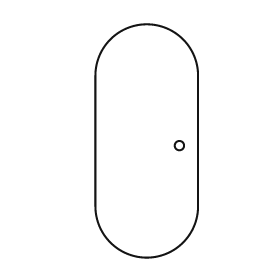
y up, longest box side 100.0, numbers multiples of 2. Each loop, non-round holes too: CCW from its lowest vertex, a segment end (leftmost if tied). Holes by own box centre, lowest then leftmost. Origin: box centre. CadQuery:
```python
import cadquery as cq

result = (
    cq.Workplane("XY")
    .moveTo(-22.0, -28.0)
    .threePointArc((0.0, -50.0), (22.0, -28.0))
    .lineTo(22.0, 28.0)
    .threePointArc((0.0, 50.0), (-22.0, 28.0))
    .close()
    .moveTo(14.0, -2.0)
    .circle(2.0)
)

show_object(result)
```